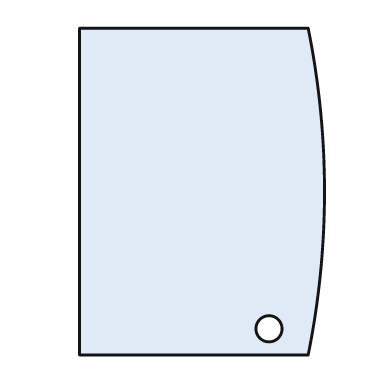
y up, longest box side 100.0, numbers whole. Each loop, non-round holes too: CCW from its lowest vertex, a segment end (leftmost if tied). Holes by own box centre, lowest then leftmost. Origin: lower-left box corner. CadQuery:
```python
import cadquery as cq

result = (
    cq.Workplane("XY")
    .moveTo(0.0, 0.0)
    .lineTo(70.0, 0.0)
    .threePointArc((75.0, 50.0), (70.0, 100.0))
    .lineTo(0.0, 100.0)
    .close()
    .moveTo(58.0, 8.0)
    .circle(4.0)
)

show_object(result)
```